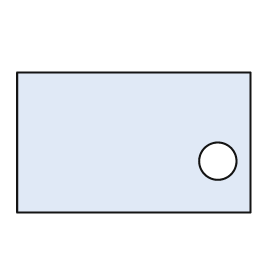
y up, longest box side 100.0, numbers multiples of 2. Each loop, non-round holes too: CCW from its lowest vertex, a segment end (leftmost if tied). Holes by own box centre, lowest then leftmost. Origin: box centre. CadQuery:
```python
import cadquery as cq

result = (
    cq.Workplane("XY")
    .moveTo(-50.0, -30.0)
    .lineTo(50.0, -30.0)
    .lineTo(50.0, 30.0)
    .lineTo(-50.0, 30.0)
    .close()
    .moveTo(36.0, -8.0)
    .circle(8.0)
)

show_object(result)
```